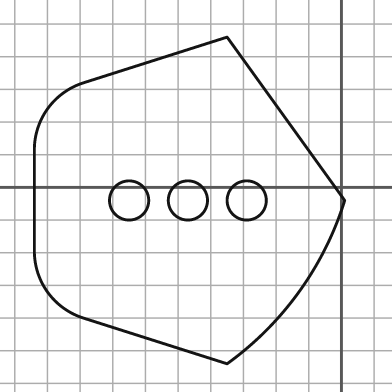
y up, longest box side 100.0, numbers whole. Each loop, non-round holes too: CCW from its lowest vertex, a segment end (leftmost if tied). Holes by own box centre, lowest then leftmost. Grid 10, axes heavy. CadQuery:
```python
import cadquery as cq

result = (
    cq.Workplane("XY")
    .moveTo(-35.0, -54.0)
    .threePointArc((-13.0, -32.0), (1.0, -4.0))
    .lineTo(-35.0, 46.0)
    .lineTo(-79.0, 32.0)
    .threePointArc((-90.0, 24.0), (-94.0, 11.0))
    .lineTo(-94.0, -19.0)
    .threePointArc((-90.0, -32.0), (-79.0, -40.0))
    .close()
    .moveTo(-65.0, -4.0)
    .circle(6.0)
    .moveTo(-47.0, -4.0)
    .circle(6.0)
    .moveTo(-29.0, -4.0)
    .circle(6.0)
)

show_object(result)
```